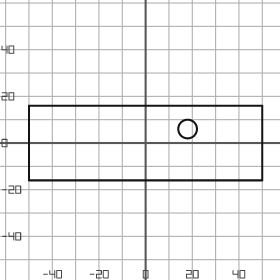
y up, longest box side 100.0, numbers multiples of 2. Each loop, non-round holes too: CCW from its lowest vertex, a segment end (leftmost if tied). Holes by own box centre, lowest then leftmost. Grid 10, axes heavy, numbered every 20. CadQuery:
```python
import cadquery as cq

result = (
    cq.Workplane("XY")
    .moveTo(-50.0, -16.0)
    .lineTo(50.0, -16.0)
    .lineTo(50.0, 16.0)
    .lineTo(-50.0, 16.0)
    .close()
    .moveTo(18.0, 6.0)
    .circle(4.0)
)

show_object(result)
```